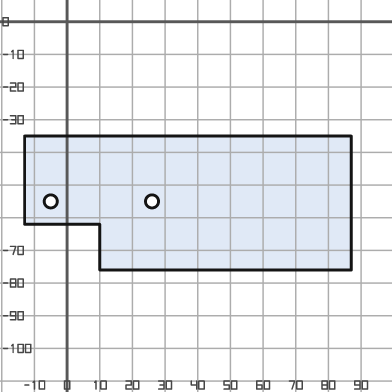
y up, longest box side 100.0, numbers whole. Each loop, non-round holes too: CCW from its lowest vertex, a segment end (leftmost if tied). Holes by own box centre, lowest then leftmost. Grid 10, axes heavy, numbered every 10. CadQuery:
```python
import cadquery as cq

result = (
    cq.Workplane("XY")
    .moveTo(10.0, -76.0)
    .lineTo(87.0, -76.0)
    .lineTo(87.0, -35.0)
    .lineTo(-13.0, -35.0)
    .lineTo(-13.0, -62.0)
    .lineTo(10.0, -62.0)
    .close()
    .moveTo(-5.0, -55.0)
    .circle(2.0)
    .moveTo(26.0, -55.0)
    .circle(2.0)
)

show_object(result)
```